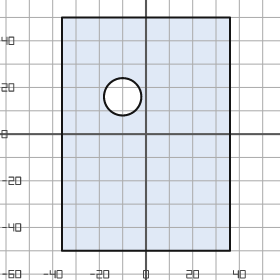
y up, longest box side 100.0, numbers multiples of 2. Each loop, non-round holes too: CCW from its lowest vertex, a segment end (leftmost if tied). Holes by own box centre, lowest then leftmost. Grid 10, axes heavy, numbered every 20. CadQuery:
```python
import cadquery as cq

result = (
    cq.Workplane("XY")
    .moveTo(-36.0, -50.0)
    .lineTo(36.0, -50.0)
    .lineTo(36.0, 50.0)
    .lineTo(-36.0, 50.0)
    .close()
    .moveTo(-10.0, 16.0)
    .circle(8.0)
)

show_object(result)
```